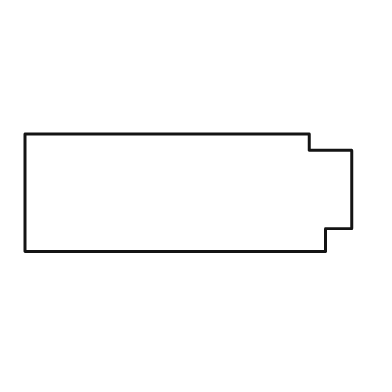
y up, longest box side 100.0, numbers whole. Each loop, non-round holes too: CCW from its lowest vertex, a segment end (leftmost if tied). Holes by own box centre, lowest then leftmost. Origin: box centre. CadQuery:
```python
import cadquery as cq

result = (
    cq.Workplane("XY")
    .moveTo(-50.0, -18.0)
    .lineTo(42.0, -18.0)
    .lineTo(42.0, -11.0)
    .lineTo(50.0, -11.0)
    .lineTo(50.0, 13.0)
    .lineTo(37.0, 13.0)
    .lineTo(37.0, 18.0)
    .lineTo(-50.0, 18.0)
    .close()
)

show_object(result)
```